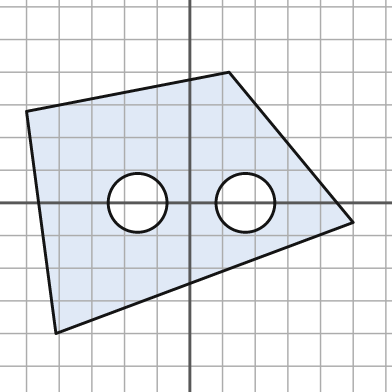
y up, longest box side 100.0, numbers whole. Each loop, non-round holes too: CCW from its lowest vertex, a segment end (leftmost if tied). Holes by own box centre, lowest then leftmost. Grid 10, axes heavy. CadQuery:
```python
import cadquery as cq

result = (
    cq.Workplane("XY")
    .moveTo(-41.0, -40.0)
    .lineTo(50.0, -6.0)
    .lineTo(12.0, 40.0)
    .lineTo(-50.0, 28.0)
    .close()
    .moveTo(-16.0, 0.0)
    .circle(9.0)
    .moveTo(17.0, 0.0)
    .circle(9.0)
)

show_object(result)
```